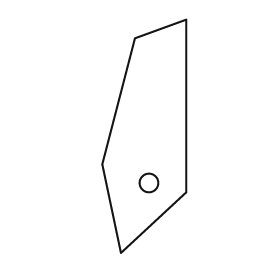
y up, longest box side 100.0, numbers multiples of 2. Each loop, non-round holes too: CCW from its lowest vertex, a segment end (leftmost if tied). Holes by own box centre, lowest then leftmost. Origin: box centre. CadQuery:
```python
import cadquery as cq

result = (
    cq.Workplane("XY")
    .moveTo(-10.0, -50.0)
    .lineTo(18.0, -24.0)
    .lineTo(18.0, 50.0)
    .lineTo(-4.0, 42.0)
    .lineTo(-18.0, -12.0)
    .close()
    .moveTo(2.0, -20.0)
    .circle(4.0)
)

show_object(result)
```